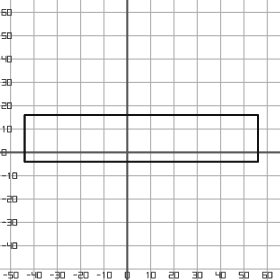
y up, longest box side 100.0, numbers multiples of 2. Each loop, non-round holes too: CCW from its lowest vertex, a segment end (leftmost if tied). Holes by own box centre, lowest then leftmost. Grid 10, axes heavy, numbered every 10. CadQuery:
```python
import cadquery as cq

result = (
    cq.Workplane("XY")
    .moveTo(-44.0, -4.0)
    .lineTo(56.0, -4.0)
    .lineTo(56.0, 16.0)
    .lineTo(-44.0, 16.0)
    .close()
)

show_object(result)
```